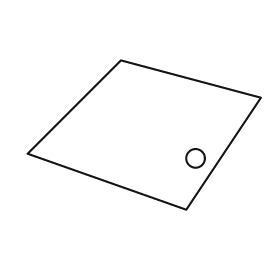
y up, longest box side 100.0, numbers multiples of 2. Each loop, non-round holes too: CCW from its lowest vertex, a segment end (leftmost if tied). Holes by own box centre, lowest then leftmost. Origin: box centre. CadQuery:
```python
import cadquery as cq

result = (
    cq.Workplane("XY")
    .moveTo(18.0, -32.0)
    .lineTo(50.0, 16.0)
    .lineTo(-10.0, 32.0)
    .lineTo(-50.0, -8.0)
    .close()
    .moveTo(22.0, -10.0)
    .circle(4.0)
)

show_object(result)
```